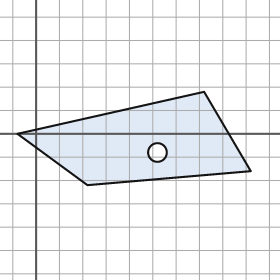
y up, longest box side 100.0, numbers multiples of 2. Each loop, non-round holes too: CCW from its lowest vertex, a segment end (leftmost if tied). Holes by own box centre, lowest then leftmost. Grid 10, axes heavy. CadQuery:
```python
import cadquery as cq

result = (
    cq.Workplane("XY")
    .moveTo(22.0, -22.0)
    .lineTo(92.0, -16.0)
    .lineTo(72.0, 18.0)
    .lineTo(-8.0, 0.0)
    .close()
    .moveTo(52.0, -8.0)
    .circle(4.0)
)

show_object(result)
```